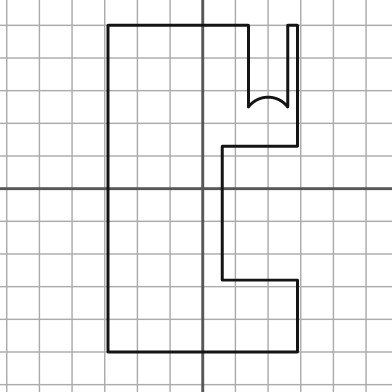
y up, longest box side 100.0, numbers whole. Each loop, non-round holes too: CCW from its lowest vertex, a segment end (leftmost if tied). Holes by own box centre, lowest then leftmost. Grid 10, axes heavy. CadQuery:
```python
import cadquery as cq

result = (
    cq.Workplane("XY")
    .moveTo(-29.0, -50.0)
    .lineTo(29.0, -50.0)
    .lineTo(29.0, -28.0)
    .lineTo(6.0, -28.0)
    .lineTo(6.0, 13.0)
    .lineTo(29.0, 13.0)
    .lineTo(29.0, 50.0)
    .lineTo(26.0, 50.0)
    .lineTo(26.0, 25.0)
    .threePointArc((20.0, 28.0), (14.0, 25.0))
    .lineTo(14.0, 50.0)
    .lineTo(-29.0, 50.0)
    .close()
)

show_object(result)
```